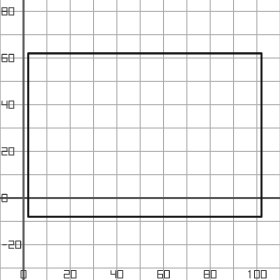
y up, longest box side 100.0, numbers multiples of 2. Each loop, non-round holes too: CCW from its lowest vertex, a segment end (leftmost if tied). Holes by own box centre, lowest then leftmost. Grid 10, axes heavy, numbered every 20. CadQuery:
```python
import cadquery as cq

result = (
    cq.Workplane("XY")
    .moveTo(2.0, -8.0)
    .lineTo(102.0, -8.0)
    .lineTo(102.0, 62.0)
    .lineTo(2.0, 62.0)
    .close()
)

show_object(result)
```